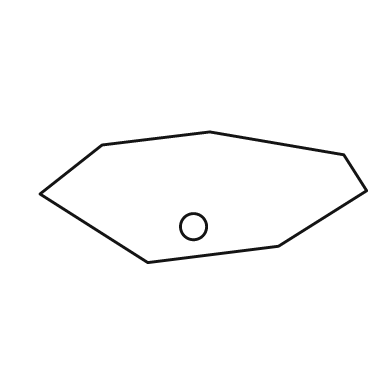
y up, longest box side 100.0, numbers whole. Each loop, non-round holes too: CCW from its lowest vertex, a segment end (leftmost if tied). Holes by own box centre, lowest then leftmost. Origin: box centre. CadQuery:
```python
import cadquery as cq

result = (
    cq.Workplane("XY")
    .moveTo(-17.0, -20.0)
    .lineTo(23.0, -15.0)
    .lineTo(50.0, 2.0)
    .lineTo(43.0, 13.0)
    .lineTo(2.0, 20.0)
    .lineTo(-31.0, 16.0)
    .lineTo(-50.0, 1.0)
    .close()
    .moveTo(-3.0, -9.0)
    .circle(4.0)
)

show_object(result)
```